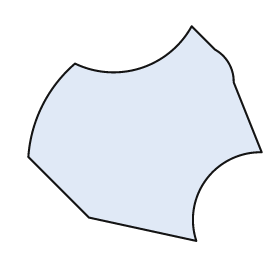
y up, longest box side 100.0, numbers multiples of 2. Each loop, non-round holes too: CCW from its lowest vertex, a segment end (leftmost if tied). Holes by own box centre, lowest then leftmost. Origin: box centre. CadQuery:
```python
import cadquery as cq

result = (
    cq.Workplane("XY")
    .moveTo(22.0, -46.0)
    .threePointArc((26.0, -20.0), (50.0, -8.0))
    .lineTo(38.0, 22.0)
    .threePointArc((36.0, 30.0), (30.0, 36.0))
    .lineTo(20.0, 46.0)
    .threePointArc((-2.0, 28.0), (-30.0, 30.0))
    .threePointArc((-44.0, 12.0), (-50.0, -10.0))
    .lineTo(-24.0, -36.0)
    .close()
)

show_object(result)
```